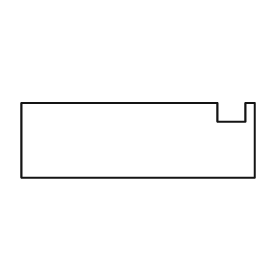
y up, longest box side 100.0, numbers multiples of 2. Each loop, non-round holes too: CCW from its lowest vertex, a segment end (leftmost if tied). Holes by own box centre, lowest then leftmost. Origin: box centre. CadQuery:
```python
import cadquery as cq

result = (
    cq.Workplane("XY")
    .moveTo(-50.0, -16.0)
    .lineTo(50.0, -16.0)
    .lineTo(50.0, 16.0)
    .lineTo(46.0, 16.0)
    .lineTo(46.0, 8.0)
    .lineTo(34.0, 8.0)
    .lineTo(34.0, 16.0)
    .lineTo(-50.0, 16.0)
    .close()
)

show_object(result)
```